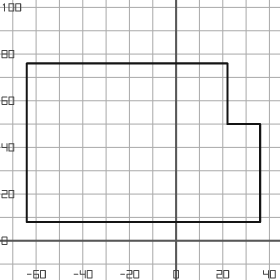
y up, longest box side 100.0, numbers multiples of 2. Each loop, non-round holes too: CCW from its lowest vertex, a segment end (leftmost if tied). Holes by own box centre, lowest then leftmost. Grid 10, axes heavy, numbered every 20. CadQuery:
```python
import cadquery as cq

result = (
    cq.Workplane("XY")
    .moveTo(-64.0, 8.0)
    .lineTo(36.0, 8.0)
    .lineTo(36.0, 50.0)
    .lineTo(22.0, 50.0)
    .lineTo(22.0, 76.0)
    .lineTo(-64.0, 76.0)
    .close()
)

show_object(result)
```